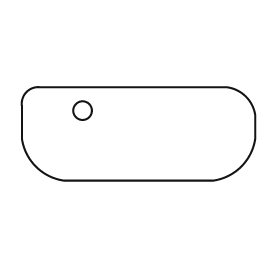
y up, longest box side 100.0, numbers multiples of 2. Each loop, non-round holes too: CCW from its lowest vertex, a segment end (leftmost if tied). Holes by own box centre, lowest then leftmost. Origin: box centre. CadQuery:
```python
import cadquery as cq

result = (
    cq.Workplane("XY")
    .moveTo(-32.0, -20.0)
    .lineTo(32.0, -20.0)
    .threePointArc((44.0, -14.0), (50.0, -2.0))
    .lineTo(50.0, 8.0)
    .threePointArc((46.0, 16.0), (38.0, 20.0))
    .lineTo(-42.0, 20.0)
    .threePointArc((-48.0, 18.0), (-50.0, 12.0))
    .lineTo(-50.0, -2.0)
    .threePointArc((-44.0, -14.0), (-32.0, -20.0))
    .close()
    .moveTo(-24.0, 10.0)
    .circle(4.0)
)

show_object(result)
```